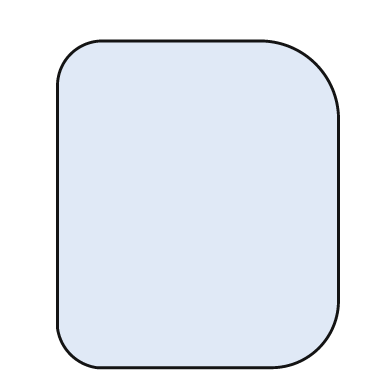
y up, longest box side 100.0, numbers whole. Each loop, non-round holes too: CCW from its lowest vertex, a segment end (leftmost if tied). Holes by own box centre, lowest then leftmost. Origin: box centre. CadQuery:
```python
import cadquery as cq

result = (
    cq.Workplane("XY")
    .moveTo(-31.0, -50.0)
    .lineTo(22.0, -50.0)
    .threePointArc((37.0, -44.0), (43.0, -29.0))
    .lineTo(43.0, 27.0)
    .threePointArc((36.0, 43.0), (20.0, 50.0))
    .lineTo(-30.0, 50.0)
    .threePointArc((-39.0, 46.0), (-43.0, 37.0))
    .lineTo(-43.0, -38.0)
    .threePointArc((-39.0, -46.0), (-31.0, -50.0))
    .close()
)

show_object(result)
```